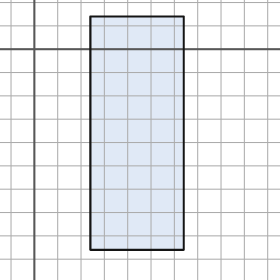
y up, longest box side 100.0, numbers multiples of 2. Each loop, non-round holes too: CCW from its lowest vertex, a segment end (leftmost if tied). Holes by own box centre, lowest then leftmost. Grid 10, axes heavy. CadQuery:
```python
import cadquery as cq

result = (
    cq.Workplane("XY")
    .moveTo(24.0, -86.0)
    .lineTo(64.0, -86.0)
    .lineTo(64.0, 14.0)
    .lineTo(24.0, 14.0)
    .close()
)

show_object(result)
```